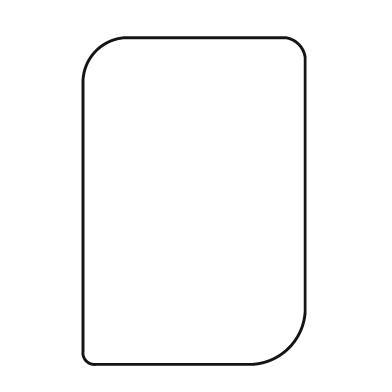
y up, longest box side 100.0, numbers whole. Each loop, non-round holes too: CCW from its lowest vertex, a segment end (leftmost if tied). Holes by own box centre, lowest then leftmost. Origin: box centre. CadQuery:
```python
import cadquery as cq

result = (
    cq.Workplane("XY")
    .moveTo(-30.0, -50.0)
    .lineTo(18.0, -50.0)
    .threePointArc((29.0, -45.0), (34.0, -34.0))
    .lineTo(34.0, 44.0)
    .threePointArc((32.0, 48.0), (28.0, 50.0))
    .lineTo(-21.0, 50.0)
    .threePointArc((-30.0, 46.0), (-34.0, 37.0))
    .lineTo(-34.0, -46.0)
    .threePointArc((-33.0, -49.0), (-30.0, -50.0))
    .close()
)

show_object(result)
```